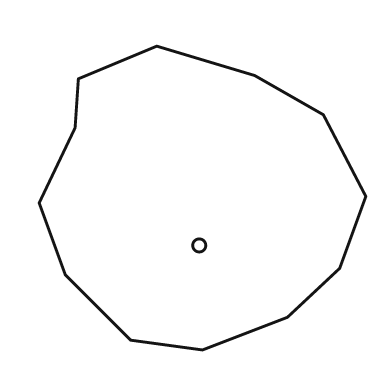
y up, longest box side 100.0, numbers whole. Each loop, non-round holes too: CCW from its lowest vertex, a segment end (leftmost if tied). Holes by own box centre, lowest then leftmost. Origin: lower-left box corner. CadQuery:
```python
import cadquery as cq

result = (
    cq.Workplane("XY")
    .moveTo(50.0, 0.0)
    .lineTo(76.0, 10.0)
    .lineTo(92.0, 25.0)
    .lineTo(100.0, 47.0)
    .lineTo(87.0, 72.0)
    .lineTo(66.0, 84.0)
    .lineTo(36.0, 93.0)
    .lineTo(12.0, 83.0)
    .lineTo(11.0, 68.0)
    .lineTo(0.0, 45.0)
    .lineTo(8.0, 23.0)
    .lineTo(28.0, 3.0)
    .close()
    .moveTo(49.0, 32.0)
    .circle(2.0)
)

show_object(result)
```